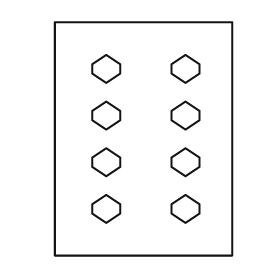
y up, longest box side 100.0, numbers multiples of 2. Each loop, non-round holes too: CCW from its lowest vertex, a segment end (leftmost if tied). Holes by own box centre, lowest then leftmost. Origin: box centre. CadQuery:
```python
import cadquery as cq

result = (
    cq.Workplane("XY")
    .moveTo(-38.0, -50.0)
    .lineTo(38.0, -50.0)
    .lineTo(38.0, 50.0)
    .lineTo(-38.0, 50.0)
    .close()
    .moveTo(-16.0, -36.0)
    .lineTo(-10.0, -32.0)
    .lineTo(-10.0, -28.0)
    .lineTo(-16.0, -24.0)
    .lineTo(-22.0, -28.0)
    .lineTo(-22.0, -32.0)
    .close()
    .moveTo(18.0, -36.0)
    .lineTo(24.0, -32.0)
    .lineTo(24.0, -28.0)
    .lineTo(18.0, -24.0)
    .lineTo(12.0, -28.0)
    .lineTo(12.0, -32.0)
    .close()
    .moveTo(-16.0, -16.0)
    .lineTo(-10.0, -12.0)
    .lineTo(-10.0, -8.0)
    .lineTo(-16.0, -4.0)
    .lineTo(-22.0, -8.0)
    .lineTo(-22.0, -12.0)
    .close()
    .moveTo(18.0, -16.0)
    .lineTo(24.0, -12.0)
    .lineTo(24.0, -8.0)
    .lineTo(18.0, -4.0)
    .lineTo(12.0, -8.0)
    .lineTo(12.0, -12.0)
    .close()
    .moveTo(-16.0, 4.0)
    .lineTo(-10.0, 8.0)
    .lineTo(-10.0, 12.0)
    .lineTo(-16.0, 16.0)
    .lineTo(-22.0, 12.0)
    .lineTo(-22.0, 8.0)
    .close()
    .moveTo(18.0, 4.0)
    .lineTo(24.0, 8.0)
    .lineTo(24.0, 12.0)
    .lineTo(18.0, 16.0)
    .lineTo(12.0, 12.0)
    .lineTo(12.0, 8.0)
    .close()
    .moveTo(-16.0, 24.0)
    .lineTo(-10.0, 28.0)
    .lineTo(-10.0, 32.0)
    .lineTo(-16.0, 36.0)
    .lineTo(-22.0, 32.0)
    .lineTo(-22.0, 28.0)
    .close()
    .moveTo(18.0, 24.0)
    .lineTo(24.0, 28.0)
    .lineTo(24.0, 32.0)
    .lineTo(18.0, 36.0)
    .lineTo(12.0, 32.0)
    .lineTo(12.0, 28.0)
    .close()
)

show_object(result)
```